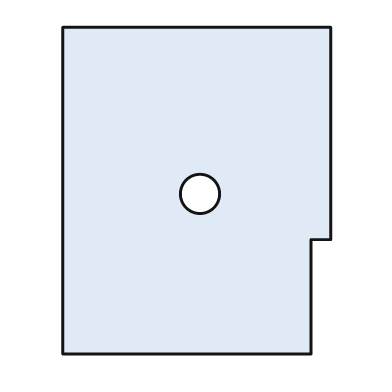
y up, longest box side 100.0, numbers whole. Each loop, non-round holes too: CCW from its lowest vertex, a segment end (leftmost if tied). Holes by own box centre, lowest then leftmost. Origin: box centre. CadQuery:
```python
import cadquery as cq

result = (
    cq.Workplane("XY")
    .moveTo(-41.0, -50.0)
    .lineTo(35.0, -50.0)
    .lineTo(35.0, -15.0)
    .lineTo(41.0, -15.0)
    .lineTo(41.0, 50.0)
    .lineTo(-41.0, 50.0)
    .close()
    .moveTo(1.0, -1.0)
    .circle(6.0)
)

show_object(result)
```